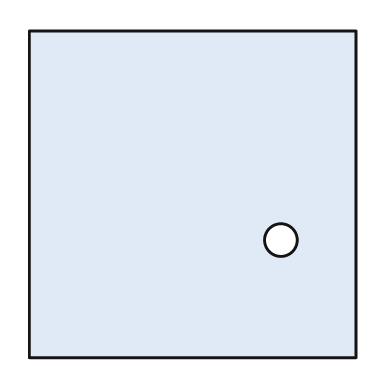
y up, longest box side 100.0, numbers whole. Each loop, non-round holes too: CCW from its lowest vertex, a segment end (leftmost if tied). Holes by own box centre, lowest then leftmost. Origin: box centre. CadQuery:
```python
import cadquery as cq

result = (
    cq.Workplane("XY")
    .moveTo(-50.0, -50.0)
    .lineTo(50.0, -50.0)
    .lineTo(50.0, 50.0)
    .lineTo(-50.0, 50.0)
    .close()
    .moveTo(27.0, -14.0)
    .circle(5.0)
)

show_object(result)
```